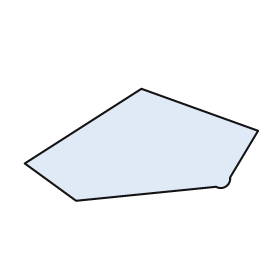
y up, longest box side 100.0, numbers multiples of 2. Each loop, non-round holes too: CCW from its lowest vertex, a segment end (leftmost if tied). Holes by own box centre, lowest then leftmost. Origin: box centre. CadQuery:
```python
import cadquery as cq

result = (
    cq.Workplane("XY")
    .moveTo(-28.0, -24.0)
    .lineTo(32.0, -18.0)
    .threePointArc((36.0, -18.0), (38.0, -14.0))
    .lineTo(50.0, 6.0)
    .lineTo(0.0, 24.0)
    .lineTo(-50.0, -8.0)
    .close()
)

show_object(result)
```